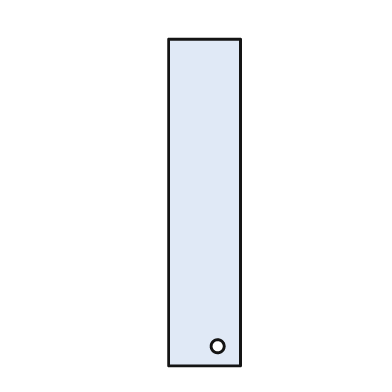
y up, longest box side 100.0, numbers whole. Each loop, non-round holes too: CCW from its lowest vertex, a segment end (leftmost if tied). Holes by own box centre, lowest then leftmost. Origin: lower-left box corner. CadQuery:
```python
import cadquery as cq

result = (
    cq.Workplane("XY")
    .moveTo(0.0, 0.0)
    .lineTo(22.0, 0.0)
    .lineTo(22.0, 100.0)
    .lineTo(0.0, 100.0)
    .close()
    .moveTo(15.0, 6.0)
    .circle(2.0)
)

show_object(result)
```